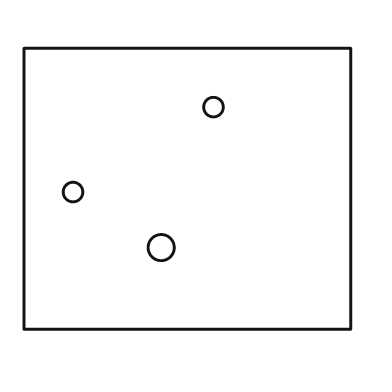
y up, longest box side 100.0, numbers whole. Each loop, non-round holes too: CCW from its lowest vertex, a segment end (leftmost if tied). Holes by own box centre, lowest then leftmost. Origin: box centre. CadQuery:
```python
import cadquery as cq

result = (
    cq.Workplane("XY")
    .moveTo(-50.0, -43.0)
    .lineTo(50.0, -43.0)
    .lineTo(50.0, 43.0)
    .lineTo(-50.0, 43.0)
    .close()
    .moveTo(-8.0, -18.0)
    .circle(4.0)
    .moveTo(-35.0, -1.0)
    .circle(3.0)
    .moveTo(8.0, 25.0)
    .circle(3.0)
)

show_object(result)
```